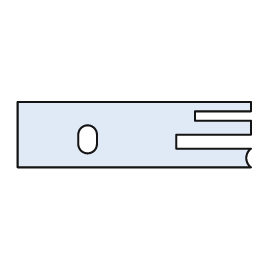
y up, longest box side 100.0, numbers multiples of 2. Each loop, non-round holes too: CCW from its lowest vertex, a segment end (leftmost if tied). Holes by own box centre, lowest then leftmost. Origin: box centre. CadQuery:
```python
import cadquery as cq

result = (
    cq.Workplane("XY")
    .moveTo(-50.0, -14.0)
    .lineTo(50.0, -14.0)
    .threePointArc((48.0, -10.0), (50.0, -6.0))
    .lineTo(18.0, -6.0)
    .lineTo(18.0, 0.0)
    .lineTo(50.0, 0.0)
    .lineTo(50.0, 6.0)
    .lineTo(26.0, 6.0)
    .lineTo(26.0, 10.0)
    .lineTo(50.0, 10.0)
    .lineTo(50.0, 14.0)
    .lineTo(-50.0, 14.0)
    .close()
    .moveTo(-24.0, -4.0)
    .threePointArc((-20.0, -8.0), (-16.0, -4.0))
    .lineTo(-16.0, 0.0)
    .threePointArc((-20.0, 4.0), (-24.0, 0.0))
    .close()
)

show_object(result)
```